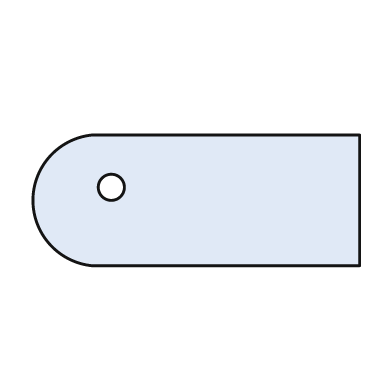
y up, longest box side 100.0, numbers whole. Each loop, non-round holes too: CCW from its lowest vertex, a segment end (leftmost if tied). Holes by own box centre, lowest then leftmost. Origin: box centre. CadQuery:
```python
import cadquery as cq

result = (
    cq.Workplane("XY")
    .moveTo(-32.0, -20.0)
    .lineTo(50.0, -20.0)
    .lineTo(50.0, 20.0)
    .lineTo(-32.0, 20.0)
    .threePointArc((-50.0, 0.0), (-32.0, -20.0))
    .close()
    .moveTo(-26.0, 4.0)
    .circle(4.0)
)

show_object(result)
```